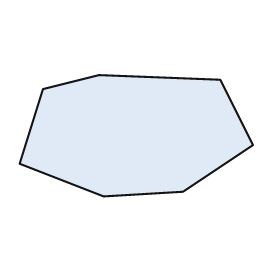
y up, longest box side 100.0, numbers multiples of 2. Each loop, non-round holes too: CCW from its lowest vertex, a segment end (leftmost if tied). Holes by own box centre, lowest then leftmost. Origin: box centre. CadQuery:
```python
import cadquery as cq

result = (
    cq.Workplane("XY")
    .moveTo(-14.0, -26.0)
    .lineTo(20.0, -24.0)
    .lineTo(50.0, -4.0)
    .lineTo(36.0, 24.0)
    .lineTo(-16.0, 26.0)
    .lineTo(-40.0, 20.0)
    .lineTo(-50.0, -12.0)
    .close()
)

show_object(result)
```